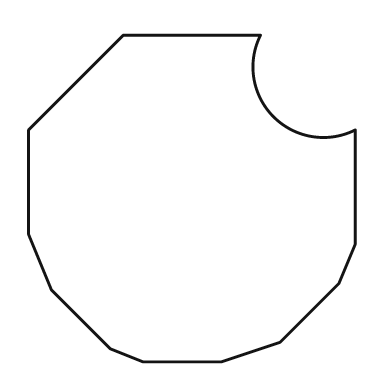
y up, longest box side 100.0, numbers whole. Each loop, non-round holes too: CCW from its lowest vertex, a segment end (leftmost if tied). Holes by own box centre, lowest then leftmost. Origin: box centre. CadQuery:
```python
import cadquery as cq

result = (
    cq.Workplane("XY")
    .moveTo(-15.0, -50.0)
    .lineTo(9.0, -50.0)
    .lineTo(27.0, -44.0)
    .lineTo(45.0, -26.0)
    .lineTo(50.0, -14.0)
    .lineTo(50.0, 21.0)
    .threePointArc((25.0, 25.0), (21.0, 50.0))
    .lineTo(-21.0, 50.0)
    .lineTo(-50.0, 21.0)
    .lineTo(-50.0, -11.0)
    .lineTo(-43.0, -28.0)
    .lineTo(-25.0, -46.0)
    .close()
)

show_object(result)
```